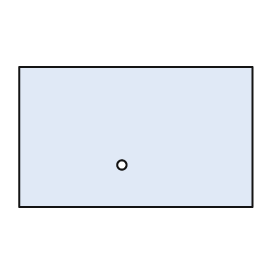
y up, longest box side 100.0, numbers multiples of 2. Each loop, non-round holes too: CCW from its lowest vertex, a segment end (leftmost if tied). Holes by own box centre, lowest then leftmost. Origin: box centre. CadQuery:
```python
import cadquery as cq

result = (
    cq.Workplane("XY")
    .moveTo(-50.0, -30.0)
    .lineTo(50.0, -30.0)
    .lineTo(50.0, 30.0)
    .lineTo(-50.0, 30.0)
    .close()
    .moveTo(-6.0, -12.0)
    .circle(2.0)
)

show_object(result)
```